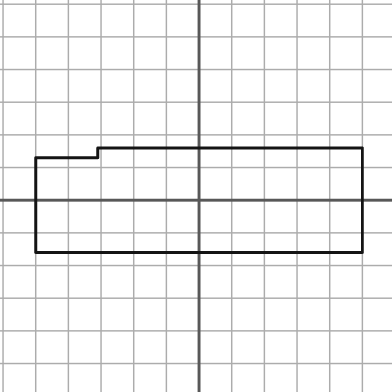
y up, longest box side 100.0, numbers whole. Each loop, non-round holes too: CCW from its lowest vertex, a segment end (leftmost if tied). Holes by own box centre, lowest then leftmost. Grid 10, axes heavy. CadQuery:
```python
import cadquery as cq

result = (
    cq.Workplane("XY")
    .moveTo(-50.0, -16.0)
    .lineTo(50.0, -16.0)
    .lineTo(50.0, 16.0)
    .lineTo(-31.0, 16.0)
    .lineTo(-31.0, 13.0)
    .lineTo(-50.0, 13.0)
    .close()
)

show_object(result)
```